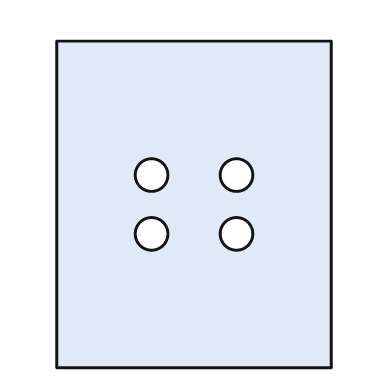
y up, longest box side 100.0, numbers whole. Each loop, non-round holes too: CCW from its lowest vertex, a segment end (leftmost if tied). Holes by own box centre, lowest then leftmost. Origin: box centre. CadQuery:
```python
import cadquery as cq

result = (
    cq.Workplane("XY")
    .moveTo(-42.0, -50.0)
    .lineTo(42.0, -50.0)
    .lineTo(42.0, 50.0)
    .lineTo(-42.0, 50.0)
    .close()
    .moveTo(-13.0, -9.0)
    .circle(5.0)
    .moveTo(13.0, -9.0)
    .circle(5.0)
    .moveTo(-13.0, 9.0)
    .circle(5.0)
    .moveTo(13.0, 9.0)
    .circle(5.0)
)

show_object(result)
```